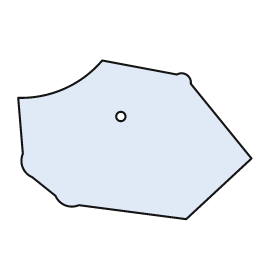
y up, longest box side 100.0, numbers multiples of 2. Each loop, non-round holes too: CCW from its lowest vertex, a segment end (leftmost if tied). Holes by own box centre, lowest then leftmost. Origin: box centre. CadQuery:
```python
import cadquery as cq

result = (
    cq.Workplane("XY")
    .moveTo(22.0, -34.0)
    .lineTo(50.0, -8.0)
    .lineTo(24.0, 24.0)
    .threePointArc((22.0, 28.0), (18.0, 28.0))
    .lineTo(-14.0, 34.0)
    .threePointArc((-30.0, 22.0), (-50.0, 18.0))
    .lineTo(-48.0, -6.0)
    .threePointArc((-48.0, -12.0), (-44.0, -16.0))
    .lineTo(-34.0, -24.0)
    .threePointArc((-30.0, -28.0), (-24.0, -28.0))
    .close()
    .moveTo(-6.0, 10.0)
    .circle(2.0)
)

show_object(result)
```